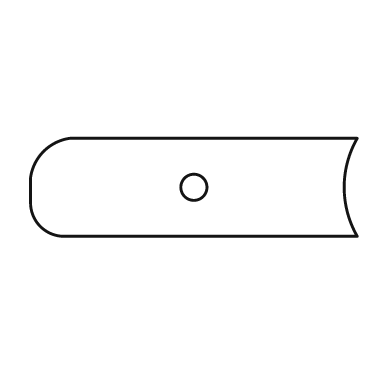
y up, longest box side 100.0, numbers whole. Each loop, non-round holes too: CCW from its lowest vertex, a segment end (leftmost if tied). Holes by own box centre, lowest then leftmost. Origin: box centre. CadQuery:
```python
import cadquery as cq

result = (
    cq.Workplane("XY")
    .moveTo(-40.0, -15.0)
    .lineTo(50.0, -15.0)
    .threePointArc((46.0, 0.0), (50.0, 15.0))
    .lineTo(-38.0, 15.0)
    .threePointArc((-46.0, 11.0), (-50.0, 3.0))
    .lineTo(-50.0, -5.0)
    .threePointArc((-47.0, -12.0), (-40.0, -15.0))
    .close()
    .moveTo(0.0, 0.0)
    .circle(4.0)
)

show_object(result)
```